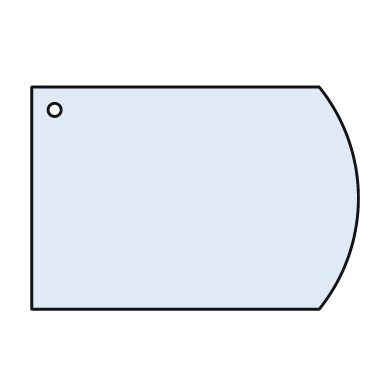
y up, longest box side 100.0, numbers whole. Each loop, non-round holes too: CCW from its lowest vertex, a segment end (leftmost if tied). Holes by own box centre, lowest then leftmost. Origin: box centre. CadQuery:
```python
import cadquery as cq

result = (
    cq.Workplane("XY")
    .moveTo(-50.0, -34.0)
    .lineTo(38.0, -34.0)
    .threePointArc((50.0, 0.0), (38.0, 34.0))
    .lineTo(-50.0, 34.0)
    .close()
    .moveTo(-43.0, 27.0)
    .circle(2.0)
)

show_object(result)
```